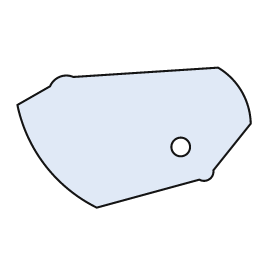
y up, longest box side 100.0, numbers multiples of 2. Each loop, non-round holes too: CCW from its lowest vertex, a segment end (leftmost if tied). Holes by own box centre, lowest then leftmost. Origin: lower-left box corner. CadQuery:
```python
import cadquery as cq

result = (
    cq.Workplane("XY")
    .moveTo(34.0, 0.0)
    .lineTo(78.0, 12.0)
    .threePointArc((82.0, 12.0), (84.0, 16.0))
    .lineTo(100.0, 36.0)
    .threePointArc((96.0, 50.0), (86.0, 60.0))
    .lineTo(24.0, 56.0)
    .threePointArc((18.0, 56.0), (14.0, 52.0))
    .lineTo(0.0, 44.0)
    .threePointArc((12.0, 18.0), (34.0, 0.0))
    .close()
    .moveTo(70.0, 26.0)
    .circle(4.0)
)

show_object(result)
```